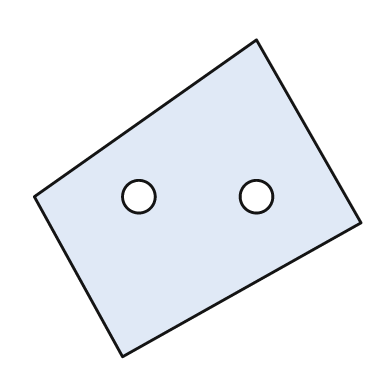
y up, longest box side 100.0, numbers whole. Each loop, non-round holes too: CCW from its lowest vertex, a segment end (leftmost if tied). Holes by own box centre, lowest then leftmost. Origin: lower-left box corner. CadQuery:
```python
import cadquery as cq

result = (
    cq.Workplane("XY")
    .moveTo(27.0, 0.0)
    .lineTo(100.0, 41.0)
    .lineTo(68.0, 97.0)
    .lineTo(0.0, 49.0)
    .close()
    .moveTo(32.0, 49.0)
    .circle(5.0)
    .moveTo(68.0, 49.0)
    .circle(5.0)
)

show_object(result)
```